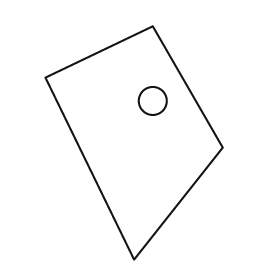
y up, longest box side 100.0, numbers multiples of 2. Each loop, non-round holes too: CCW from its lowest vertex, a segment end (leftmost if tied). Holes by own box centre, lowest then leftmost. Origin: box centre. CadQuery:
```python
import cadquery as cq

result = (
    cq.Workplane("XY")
    .moveTo(0.0, -50.0)
    .lineTo(38.0, -2.0)
    .lineTo(8.0, 50.0)
    .lineTo(-38.0, 28.0)
    .close()
    .moveTo(8.0, 18.0)
    .circle(6.0)
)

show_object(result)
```